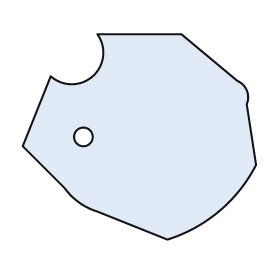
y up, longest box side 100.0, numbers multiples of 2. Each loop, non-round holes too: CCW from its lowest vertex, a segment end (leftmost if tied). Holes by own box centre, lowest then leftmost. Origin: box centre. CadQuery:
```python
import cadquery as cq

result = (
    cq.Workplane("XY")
    .moveTo(12.0, -44.0)
    .threePointArc((34.0, -32.0), (50.0, -12.0))
    .lineTo(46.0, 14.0)
    .threePointArc((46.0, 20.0), (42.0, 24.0))
    .lineTo(18.0, 44.0)
    .lineTo(-18.0, 44.0)
    .threePointArc((-20.0, 26.0), (-38.0, 26.0))
    .lineTo(-50.0, -4.0)
    .lineTo(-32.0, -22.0)
    .threePointArc((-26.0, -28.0), (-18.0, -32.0))
    .close()
    .moveTo(-24.0, 0.0)
    .circle(4.0)
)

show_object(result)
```